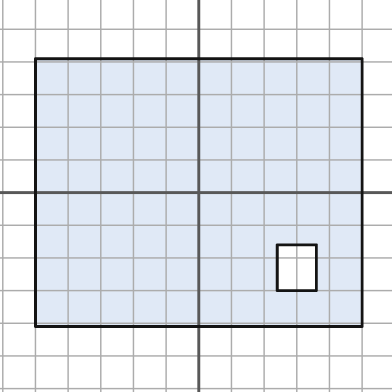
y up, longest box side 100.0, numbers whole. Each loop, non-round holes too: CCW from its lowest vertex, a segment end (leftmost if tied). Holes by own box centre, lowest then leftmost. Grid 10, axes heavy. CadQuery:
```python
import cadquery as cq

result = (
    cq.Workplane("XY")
    .moveTo(-50.0, -41.0)
    .lineTo(50.0, -41.0)
    .lineTo(50.0, 41.0)
    .lineTo(-50.0, 41.0)
    .close()
    .moveTo(24.0, -30.0)
    .lineTo(36.0, -30.0)
    .lineTo(36.0, -16.0)
    .lineTo(24.0, -16.0)
    .close()
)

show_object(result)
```